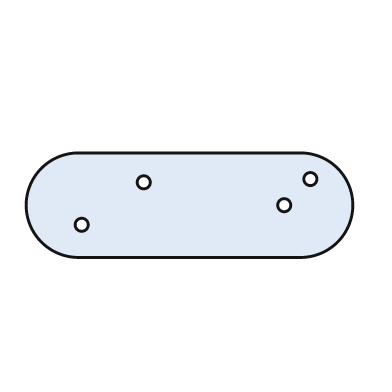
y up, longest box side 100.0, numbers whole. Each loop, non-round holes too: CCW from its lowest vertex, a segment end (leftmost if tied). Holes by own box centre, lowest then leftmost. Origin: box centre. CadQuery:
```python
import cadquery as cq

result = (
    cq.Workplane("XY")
    .moveTo(-34.0, -16.0)
    .lineTo(34.0, -16.0)
    .threePointArc((50.0, 0.0), (34.0, 16.0))
    .lineTo(-34.0, 16.0)
    .threePointArc((-50.0, 0.0), (-34.0, -16.0))
    .close()
    .moveTo(-33.0, -6.0)
    .circle(2.0)
    .moveTo(29.0, 0.0)
    .circle(2.0)
    .moveTo(-14.0, 7.0)
    .circle(2.0)
    .moveTo(37.0, 8.0)
    .circle(2.0)
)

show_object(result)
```